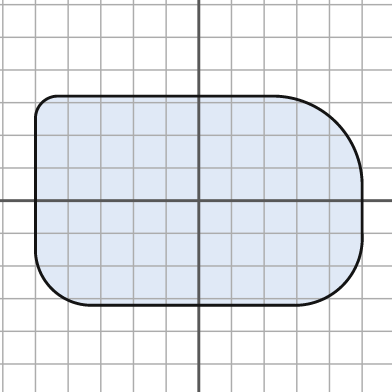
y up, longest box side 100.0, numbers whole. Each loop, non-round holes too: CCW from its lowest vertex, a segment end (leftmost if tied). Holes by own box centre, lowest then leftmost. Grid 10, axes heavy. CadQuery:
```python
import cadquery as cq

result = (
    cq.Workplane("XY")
    .moveTo(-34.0, -32.0)
    .lineTo(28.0, -32.0)
    .threePointArc((44.0, -26.0), (50.0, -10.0))
    .lineTo(50.0, 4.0)
    .threePointArc((42.0, 24.0), (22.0, 32.0))
    .lineTo(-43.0, 32.0)
    .threePointArc((-48.0, 30.0), (-50.0, 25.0))
    .lineTo(-50.0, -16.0)
    .threePointArc((-45.0, -27.0), (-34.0, -32.0))
    .close()
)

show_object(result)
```